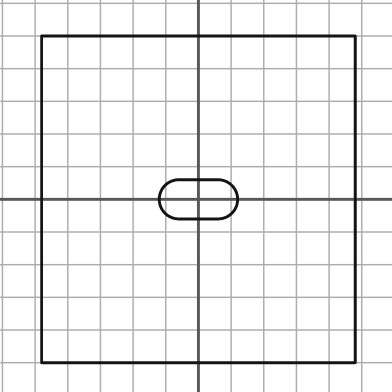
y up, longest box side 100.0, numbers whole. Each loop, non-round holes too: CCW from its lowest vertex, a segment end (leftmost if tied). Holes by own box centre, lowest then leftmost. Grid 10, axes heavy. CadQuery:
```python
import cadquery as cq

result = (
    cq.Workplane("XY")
    .moveTo(-48.0, -50.0)
    .lineTo(48.0, -50.0)
    .lineTo(48.0, 50.0)
    .lineTo(-48.0, 50.0)
    .close()
    .moveTo(-6.0, -6.0)
    .lineTo(6.0, -6.0)
    .threePointArc((12.0, 0.0), (6.0, 6.0))
    .lineTo(-6.0, 6.0)
    .threePointArc((-12.0, 0.0), (-6.0, -6.0))
    .close()
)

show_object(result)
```